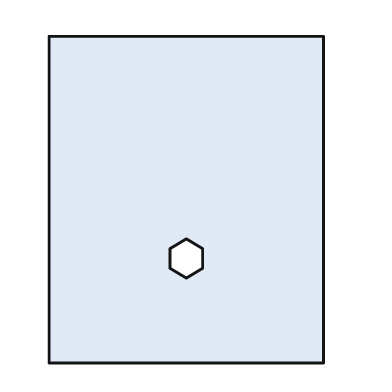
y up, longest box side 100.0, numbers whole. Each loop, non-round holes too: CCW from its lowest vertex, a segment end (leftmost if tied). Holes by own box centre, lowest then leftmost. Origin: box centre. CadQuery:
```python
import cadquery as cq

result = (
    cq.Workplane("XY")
    .moveTo(-42.0, -50.0)
    .lineTo(42.0, -50.0)
    .lineTo(42.0, 50.0)
    .lineTo(-42.0, 50.0)
    .close()
    .moveTo(0.0, -24.0)
    .lineTo(5.0, -21.0)
    .lineTo(5.0, -15.0)
    .lineTo(0.0, -12.0)
    .lineTo(-5.0, -15.0)
    .lineTo(-5.0, -21.0)
    .close()
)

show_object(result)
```